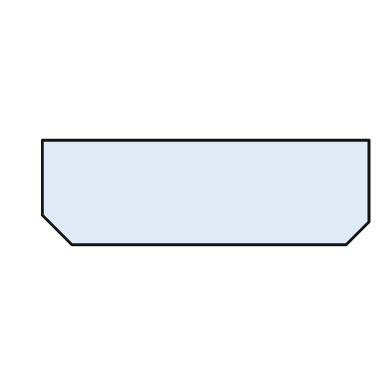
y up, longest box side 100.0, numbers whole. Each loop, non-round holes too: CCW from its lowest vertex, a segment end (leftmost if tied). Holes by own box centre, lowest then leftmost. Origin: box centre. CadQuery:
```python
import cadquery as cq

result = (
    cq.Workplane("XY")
    .moveTo(-41.0, -16.0)
    .lineTo(43.0, -16.0)
    .lineTo(50.0, -9.0)
    .lineTo(50.0, 16.0)
    .lineTo(-50.0, 16.0)
    .lineTo(-50.0, -7.0)
    .close()
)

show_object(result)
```